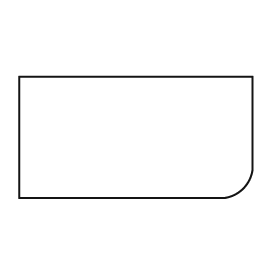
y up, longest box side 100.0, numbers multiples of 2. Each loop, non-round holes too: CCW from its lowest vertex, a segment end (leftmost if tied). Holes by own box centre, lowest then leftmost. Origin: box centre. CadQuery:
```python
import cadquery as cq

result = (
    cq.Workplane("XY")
    .moveTo(-50.0, -26.0)
    .lineTo(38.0, -26.0)
    .threePointArc((46.0, -22.0), (50.0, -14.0))
    .lineTo(50.0, 26.0)
    .lineTo(-50.0, 26.0)
    .close()
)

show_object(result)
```